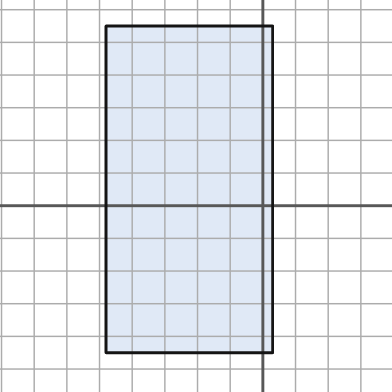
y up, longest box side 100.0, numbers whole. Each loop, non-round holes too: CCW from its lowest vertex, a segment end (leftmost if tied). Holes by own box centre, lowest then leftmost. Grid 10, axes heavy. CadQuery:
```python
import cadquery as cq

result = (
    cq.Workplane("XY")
    .moveTo(-48.0, -45.0)
    .lineTo(3.0, -45.0)
    .lineTo(3.0, 55.0)
    .lineTo(-48.0, 55.0)
    .close()
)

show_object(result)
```